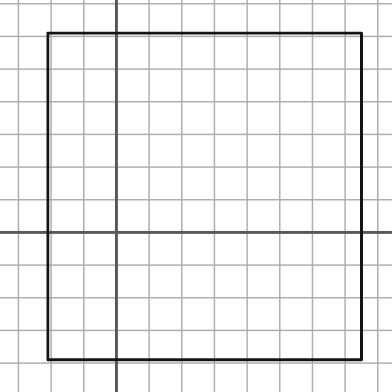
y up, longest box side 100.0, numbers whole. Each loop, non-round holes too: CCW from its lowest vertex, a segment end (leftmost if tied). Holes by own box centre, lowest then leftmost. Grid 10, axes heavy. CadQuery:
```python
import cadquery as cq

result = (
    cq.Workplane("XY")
    .moveTo(-21.0, -39.0)
    .lineTo(75.0, -39.0)
    .lineTo(75.0, 61.0)
    .lineTo(-21.0, 61.0)
    .close()
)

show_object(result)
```